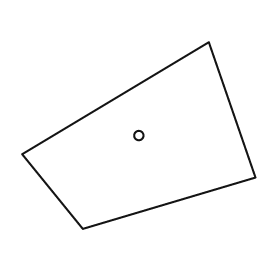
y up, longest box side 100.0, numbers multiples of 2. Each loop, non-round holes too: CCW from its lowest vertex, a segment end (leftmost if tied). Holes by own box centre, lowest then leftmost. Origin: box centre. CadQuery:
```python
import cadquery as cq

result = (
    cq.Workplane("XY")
    .moveTo(-24.0, -40.0)
    .lineTo(50.0, -18.0)
    .lineTo(30.0, 40.0)
    .lineTo(-50.0, -8.0)
    .close()
    .moveTo(0.0, 0.0)
    .circle(2.0)
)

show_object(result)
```